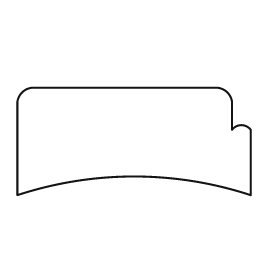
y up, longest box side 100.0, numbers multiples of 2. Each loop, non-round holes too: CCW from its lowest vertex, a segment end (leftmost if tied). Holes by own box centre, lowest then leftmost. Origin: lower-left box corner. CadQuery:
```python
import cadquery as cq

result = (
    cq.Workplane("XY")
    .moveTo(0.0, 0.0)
    .threePointArc((50.0, 8.0), (100.0, 0.0))
    .lineTo(100.0, 28.0)
    .threePointArc((96.0, 30.0), (92.0, 28.0))
    .lineTo(92.0, 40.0)
    .threePointArc((90.0, 44.0), (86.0, 46.0))
    .lineTo(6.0, 46.0)
    .threePointArc((2.0, 44.0), (0.0, 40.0))
    .close()
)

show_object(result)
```